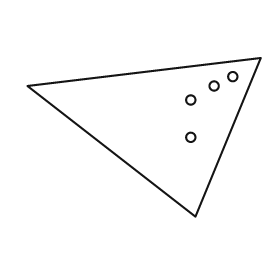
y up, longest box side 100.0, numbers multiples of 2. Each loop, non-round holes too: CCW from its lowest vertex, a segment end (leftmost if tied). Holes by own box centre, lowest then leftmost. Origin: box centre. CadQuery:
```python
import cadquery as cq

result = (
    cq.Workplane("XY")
    .moveTo(22.0, -34.0)
    .lineTo(50.0, 34.0)
    .lineTo(-50.0, 22.0)
    .close()
    .moveTo(20.0, 0.0)
    .circle(2.0)
    .moveTo(20.0, 16.0)
    .circle(2.0)
    .moveTo(30.0, 22.0)
    .circle(2.0)
    .moveTo(38.0, 26.0)
    .circle(2.0)
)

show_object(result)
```